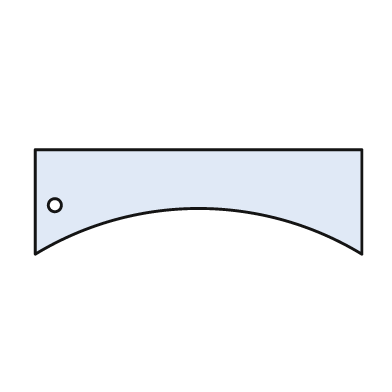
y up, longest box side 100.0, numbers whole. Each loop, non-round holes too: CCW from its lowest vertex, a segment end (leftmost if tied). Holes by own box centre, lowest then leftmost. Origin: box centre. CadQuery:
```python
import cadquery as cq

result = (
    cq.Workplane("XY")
    .moveTo(-50.0, -16.0)
    .threePointArc((0.0, -2.0), (50.0, -16.0))
    .lineTo(50.0, 16.0)
    .lineTo(-50.0, 16.0)
    .close()
    .moveTo(-44.0, -1.0)
    .circle(2.0)
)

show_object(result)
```